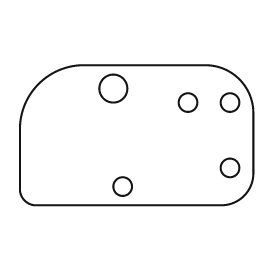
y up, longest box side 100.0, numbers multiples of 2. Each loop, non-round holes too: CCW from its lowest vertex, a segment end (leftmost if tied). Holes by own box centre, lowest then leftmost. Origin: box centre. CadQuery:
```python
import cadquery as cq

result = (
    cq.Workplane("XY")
    .moveTo(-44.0, -30.0)
    .lineTo(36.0, -30.0)
    .threePointArc((46.0, -26.0), (50.0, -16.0))
    .lineTo(50.0, 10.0)
    .threePointArc((44.0, 24.0), (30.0, 30.0))
    .lineTo(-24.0, 30.0)
    .threePointArc((-42.0, 22.0), (-50.0, 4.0))
    .lineTo(-50.0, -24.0)
    .threePointArc((-48.0, -28.0), (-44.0, -30.0))
    .close()
    .moveTo(-6.0, -22.0)
    .circle(4.0)
    .moveTo(40.0, -14.0)
    .circle(4.0)
    .moveTo(22.0, 14.0)
    .circle(4.0)
    .moveTo(40.0, 14.0)
    .circle(4.0)
    .moveTo(-10.0, 20.0)
    .circle(6.0)
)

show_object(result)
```